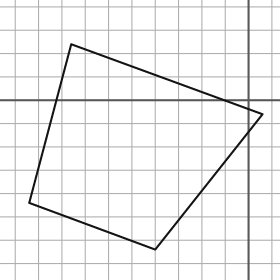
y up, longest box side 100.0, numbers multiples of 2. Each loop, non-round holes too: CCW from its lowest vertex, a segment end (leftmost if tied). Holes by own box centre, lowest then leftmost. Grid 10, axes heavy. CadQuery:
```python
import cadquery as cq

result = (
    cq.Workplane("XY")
    .moveTo(-40.0, -64.0)
    .lineTo(6.0, -6.0)
    .lineTo(-76.0, 24.0)
    .lineTo(-94.0, -44.0)
    .close()
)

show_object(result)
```